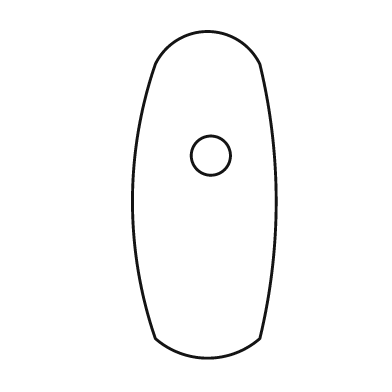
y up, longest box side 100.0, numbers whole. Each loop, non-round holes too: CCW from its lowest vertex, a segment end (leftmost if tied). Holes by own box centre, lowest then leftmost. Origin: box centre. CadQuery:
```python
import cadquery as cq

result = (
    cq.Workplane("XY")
    .moveTo(-15.0, -44.0)
    .threePointArc((1.0, -50.0), (17.0, -44.0))
    .threePointArc((22.0, -2.0), (17.0, 40.0))
    .threePointArc((1.0, 50.0), (-15.0, 40.0))
    .threePointArc((-22.0, -2.0), (-15.0, -44.0))
    .close()
    .moveTo(2.0, 12.0)
    .circle(6.0)
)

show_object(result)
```